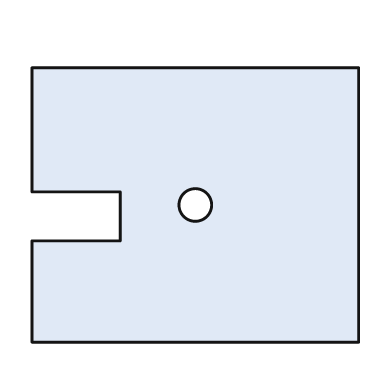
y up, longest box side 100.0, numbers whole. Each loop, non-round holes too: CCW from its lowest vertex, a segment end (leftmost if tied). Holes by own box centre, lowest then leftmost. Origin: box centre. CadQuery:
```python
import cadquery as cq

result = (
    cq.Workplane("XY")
    .moveTo(-50.0, -42.0)
    .lineTo(50.0, -42.0)
    .lineTo(50.0, 42.0)
    .lineTo(-50.0, 42.0)
    .lineTo(-50.0, 4.0)
    .lineTo(-23.0, 4.0)
    .lineTo(-23.0, -11.0)
    .lineTo(-50.0, -11.0)
    .close()
    .moveTo(0.0, 0.0)
    .circle(5.0)
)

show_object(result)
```